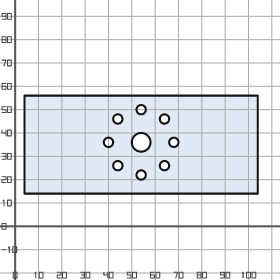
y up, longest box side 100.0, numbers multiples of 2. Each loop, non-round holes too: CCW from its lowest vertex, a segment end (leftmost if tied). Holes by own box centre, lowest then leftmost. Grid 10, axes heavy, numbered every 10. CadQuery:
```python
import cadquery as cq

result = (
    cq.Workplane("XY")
    .moveTo(4.0, 14.0)
    .lineTo(104.0, 14.0)
    .lineTo(104.0, 56.0)
    .lineTo(4.0, 56.0)
    .close()
    .moveTo(54.0, 22.0)
    .circle(2.0)
    .moveTo(44.0, 26.0)
    .circle(2.0)
    .moveTo(64.0, 26.0)
    .circle(2.0)
    .moveTo(40.0, 36.0)
    .circle(2.0)
    .moveTo(54.0, 36.0)
    .circle(4.0)
    .moveTo(68.0, 36.0)
    .circle(2.0)
    .moveTo(44.0, 46.0)
    .circle(2.0)
    .moveTo(64.0, 46.0)
    .circle(2.0)
    .moveTo(54.0, 50.0)
    .circle(2.0)
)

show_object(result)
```